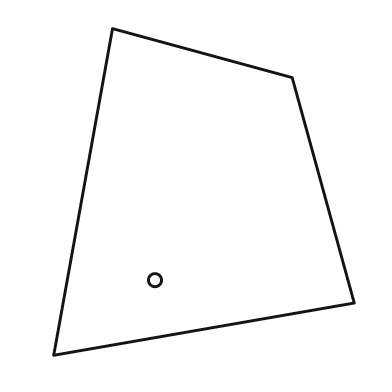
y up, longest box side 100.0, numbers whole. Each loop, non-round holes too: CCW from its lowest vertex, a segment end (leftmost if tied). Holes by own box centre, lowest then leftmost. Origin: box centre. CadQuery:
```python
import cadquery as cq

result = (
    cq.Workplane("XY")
    .moveTo(-46.0, -50.0)
    .lineTo(46.0, -34.0)
    .lineTo(27.0, 35.0)
    .lineTo(-28.0, 50.0)
    .close()
    .moveTo(-15.0, -27.0)
    .circle(2.0)
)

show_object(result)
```